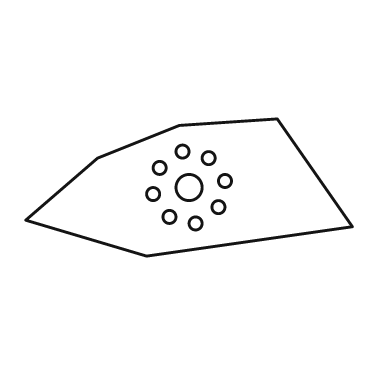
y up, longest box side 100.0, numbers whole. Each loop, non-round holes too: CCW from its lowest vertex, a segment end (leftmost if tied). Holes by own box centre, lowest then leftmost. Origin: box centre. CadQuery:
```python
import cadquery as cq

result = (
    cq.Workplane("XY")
    .moveTo(-13.0, -21.0)
    .lineTo(50.0, -12.0)
    .lineTo(27.0, 21.0)
    .lineTo(-3.0, 19.0)
    .lineTo(-28.0, 9.0)
    .lineTo(-50.0, -10.0)
    .close()
    .moveTo(2.0, -11.0)
    .circle(2.0)
    .moveTo(-6.0, -9.0)
    .circle(2.0)
    .moveTo(9.0, -6.0)
    .circle(2.0)
    .moveTo(-11.0, -2.0)
    .circle(2.0)
    .moveTo(0.0, 0.0)
    .circle(4.0)
    .moveTo(11.0, 2.0)
    .circle(2.0)
    .moveTo(-9.0, 6.0)
    .circle(2.0)
    .moveTo(6.0, 9.0)
    .circle(2.0)
    .moveTo(-2.0, 11.0)
    .circle(2.0)
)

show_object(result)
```